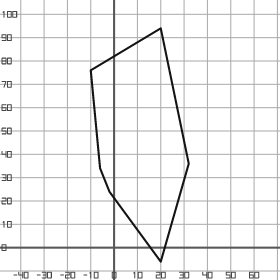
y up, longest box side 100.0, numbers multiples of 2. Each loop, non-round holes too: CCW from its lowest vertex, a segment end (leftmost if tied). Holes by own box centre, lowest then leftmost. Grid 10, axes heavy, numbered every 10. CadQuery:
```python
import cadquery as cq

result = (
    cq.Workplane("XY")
    .moveTo(20.0, -6.0)
    .lineTo(32.0, 36.0)
    .lineTo(20.0, 94.0)
    .lineTo(-10.0, 76.0)
    .lineTo(-6.0, 34.0)
    .lineTo(-2.0, 24.0)
    .close()
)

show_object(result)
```